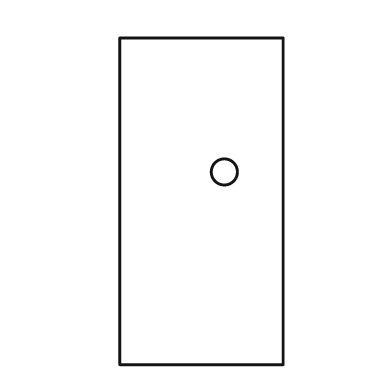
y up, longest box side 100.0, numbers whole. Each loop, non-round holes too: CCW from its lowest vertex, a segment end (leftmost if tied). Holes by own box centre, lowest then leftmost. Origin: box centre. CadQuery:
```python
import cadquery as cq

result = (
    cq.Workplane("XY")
    .moveTo(-25.0, -50.0)
    .lineTo(25.0, -50.0)
    .lineTo(25.0, 50.0)
    .lineTo(-25.0, 50.0)
    .close()
    .moveTo(7.0, 9.0)
    .circle(4.0)
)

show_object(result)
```